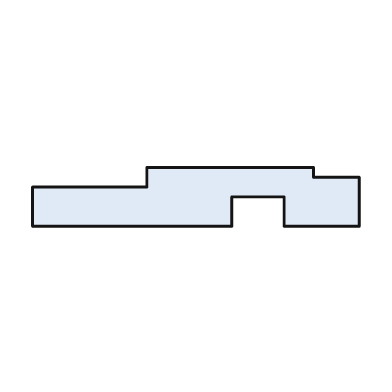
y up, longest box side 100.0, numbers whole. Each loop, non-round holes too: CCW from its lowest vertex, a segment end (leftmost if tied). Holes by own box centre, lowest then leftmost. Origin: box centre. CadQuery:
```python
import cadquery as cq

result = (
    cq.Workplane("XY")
    .moveTo(-50.0, -9.0)
    .lineTo(11.0, -9.0)
    .lineTo(11.0, 0.0)
    .lineTo(27.0, 0.0)
    .lineTo(27.0, -9.0)
    .lineTo(50.0, -9.0)
    .lineTo(50.0, 6.0)
    .lineTo(36.0, 6.0)
    .lineTo(36.0, 9.0)
    .lineTo(-15.0, 9.0)
    .lineTo(-15.0, 3.0)
    .lineTo(-50.0, 3.0)
    .close()
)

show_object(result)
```